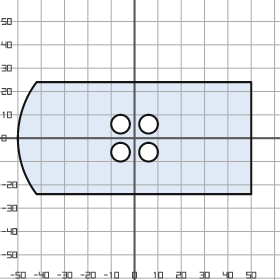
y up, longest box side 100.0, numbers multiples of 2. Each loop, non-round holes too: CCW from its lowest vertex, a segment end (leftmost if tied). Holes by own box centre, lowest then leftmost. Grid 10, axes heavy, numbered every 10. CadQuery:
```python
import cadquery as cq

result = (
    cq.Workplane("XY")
    .moveTo(-42.0, -24.0)
    .lineTo(50.0, -24.0)
    .lineTo(50.0, 24.0)
    .lineTo(-42.0, 24.0)
    .threePointArc((-50.0, 0.0), (-42.0, -24.0))
    .close()
    .moveTo(-6.0, -6.0)
    .circle(4.0)
    .moveTo(6.0, -6.0)
    .circle(4.0)
    .moveTo(-6.0, 6.0)
    .circle(4.0)
    .moveTo(6.0, 6.0)
    .circle(4.0)
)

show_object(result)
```